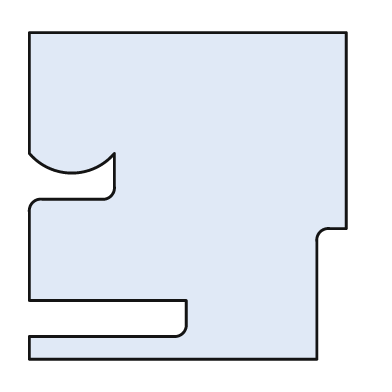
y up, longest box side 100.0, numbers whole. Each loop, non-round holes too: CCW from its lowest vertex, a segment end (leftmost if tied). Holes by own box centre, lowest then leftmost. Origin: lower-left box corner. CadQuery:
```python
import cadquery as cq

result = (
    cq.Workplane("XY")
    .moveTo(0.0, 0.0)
    .lineTo(88.0, 0.0)
    .lineTo(88.0, 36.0)
    .threePointArc((89.0, 39.0), (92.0, 40.0))
    .lineTo(97.0, 40.0)
    .lineTo(97.0, 100.0)
    .lineTo(0.0, 100.0)
    .lineTo(0.0, 63.0)
    .threePointArc((13.0, 57.0), (26.0, 63.0))
    .lineTo(26.0, 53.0)
    .threePointArc((25.0, 50.0), (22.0, 49.0))
    .lineTo(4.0, 49.0)
    .threePointArc((1.0, 48.0), (0.0, 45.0))
    .lineTo(0.0, 18.0)
    .lineTo(48.0, 18.0)
    .lineTo(48.0, 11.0)
    .threePointArc((47.0, 8.0), (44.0, 7.0))
    .lineTo(0.0, 7.0)
    .close()
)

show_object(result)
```